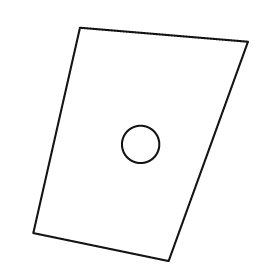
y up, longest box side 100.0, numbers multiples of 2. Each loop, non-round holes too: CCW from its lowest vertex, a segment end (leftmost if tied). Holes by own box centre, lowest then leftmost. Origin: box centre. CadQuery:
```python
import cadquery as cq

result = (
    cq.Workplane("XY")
    .moveTo(12.0, -50.0)
    .lineTo(46.0, 44.0)
    .lineTo(-26.0, 50.0)
    .lineTo(-46.0, -38.0)
    .close()
    .moveTo(0.0, 0.0)
    .circle(8.0)
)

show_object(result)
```